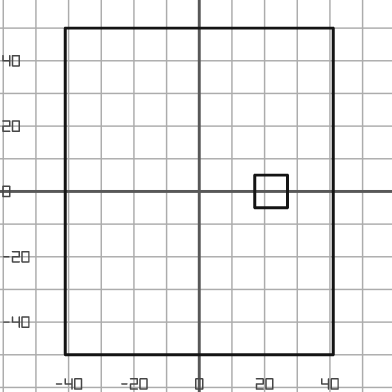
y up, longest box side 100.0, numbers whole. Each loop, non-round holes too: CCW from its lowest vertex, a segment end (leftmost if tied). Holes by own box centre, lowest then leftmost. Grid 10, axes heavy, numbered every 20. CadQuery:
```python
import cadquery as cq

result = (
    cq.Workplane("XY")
    .moveTo(-41.0, -50.0)
    .lineTo(41.0, -50.0)
    .lineTo(41.0, 50.0)
    .lineTo(-41.0, 50.0)
    .close()
    .moveTo(17.0, -5.0)
    .lineTo(27.0, -5.0)
    .lineTo(27.0, 5.0)
    .lineTo(17.0, 5.0)
    .close()
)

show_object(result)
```